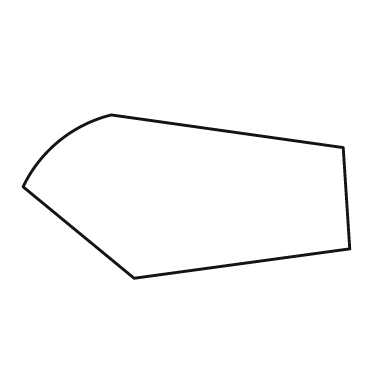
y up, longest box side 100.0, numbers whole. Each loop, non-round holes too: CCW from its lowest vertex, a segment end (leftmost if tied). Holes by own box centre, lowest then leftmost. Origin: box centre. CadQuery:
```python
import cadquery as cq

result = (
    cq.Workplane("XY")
    .moveTo(-16.0, -25.0)
    .lineTo(50.0, -16.0)
    .lineTo(48.0, 15.0)
    .lineTo(-23.0, 25.0)
    .threePointArc((-39.0, 17.0), (-50.0, 3.0))
    .close()
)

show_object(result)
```